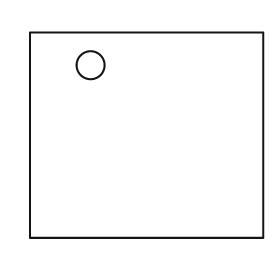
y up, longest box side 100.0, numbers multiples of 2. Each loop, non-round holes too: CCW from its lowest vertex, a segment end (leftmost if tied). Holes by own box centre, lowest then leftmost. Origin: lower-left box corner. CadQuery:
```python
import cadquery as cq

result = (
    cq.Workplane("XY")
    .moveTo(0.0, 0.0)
    .lineTo(100.0, 0.0)
    .lineTo(100.0, 88.0)
    .lineTo(0.0, 88.0)
    .close()
    .moveTo(26.0, 74.0)
    .circle(6.0)
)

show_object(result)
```